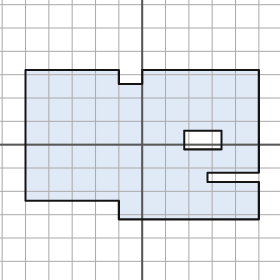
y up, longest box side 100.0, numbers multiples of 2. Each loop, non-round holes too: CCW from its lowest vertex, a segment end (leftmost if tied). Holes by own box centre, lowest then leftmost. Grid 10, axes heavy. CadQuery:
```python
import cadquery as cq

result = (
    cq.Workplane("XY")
    .moveTo(-10.0, -32.0)
    .lineTo(50.0, -32.0)
    .lineTo(50.0, -16.0)
    .lineTo(28.0, -16.0)
    .lineTo(28.0, -12.0)
    .lineTo(50.0, -12.0)
    .lineTo(50.0, 32.0)
    .lineTo(0.0, 32.0)
    .lineTo(0.0, 26.0)
    .lineTo(-10.0, 26.0)
    .lineTo(-10.0, 32.0)
    .lineTo(-50.0, 32.0)
    .lineTo(-50.0, -24.0)
    .lineTo(-10.0, -24.0)
    .close()
    .moveTo(18.0, -2.0)
    .lineTo(34.0, -2.0)
    .lineTo(34.0, 6.0)
    .lineTo(18.0, 6.0)
    .close()
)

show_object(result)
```